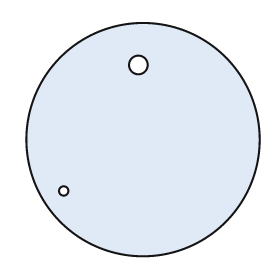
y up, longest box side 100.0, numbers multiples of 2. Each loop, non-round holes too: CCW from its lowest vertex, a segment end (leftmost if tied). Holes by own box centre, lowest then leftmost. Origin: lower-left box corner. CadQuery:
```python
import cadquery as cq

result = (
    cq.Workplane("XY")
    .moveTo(50.0, 50.0)
    .circle(50.0)
    .moveTo(16.0, 28.0)
    .circle(2.0)
    .moveTo(48.0, 82.0)
    .circle(4.0)
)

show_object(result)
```